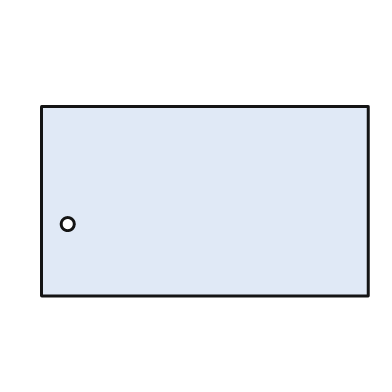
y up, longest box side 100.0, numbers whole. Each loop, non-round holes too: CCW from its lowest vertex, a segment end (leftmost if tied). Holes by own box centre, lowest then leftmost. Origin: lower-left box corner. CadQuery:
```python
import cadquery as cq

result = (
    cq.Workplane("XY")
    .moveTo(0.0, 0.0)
    .lineTo(100.0, 0.0)
    .lineTo(100.0, 58.0)
    .lineTo(0.0, 58.0)
    .close()
    .moveTo(8.0, 22.0)
    .circle(2.0)
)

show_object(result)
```